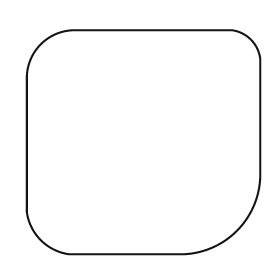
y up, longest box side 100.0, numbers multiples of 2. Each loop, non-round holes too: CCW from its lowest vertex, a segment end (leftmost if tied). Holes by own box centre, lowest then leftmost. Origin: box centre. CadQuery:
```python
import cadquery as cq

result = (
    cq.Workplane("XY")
    .moveTo(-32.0, -48.0)
    .lineTo(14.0, -48.0)
    .threePointArc((40.0, -38.0), (50.0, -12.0))
    .lineTo(50.0, 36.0)
    .threePointArc((46.0, 44.0), (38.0, 48.0))
    .lineTo(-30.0, 48.0)
    .threePointArc((-44.0, 42.0), (-50.0, 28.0))
    .lineTo(-50.0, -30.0)
    .threePointArc((-44.0, -42.0), (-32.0, -48.0))
    .close()
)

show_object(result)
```